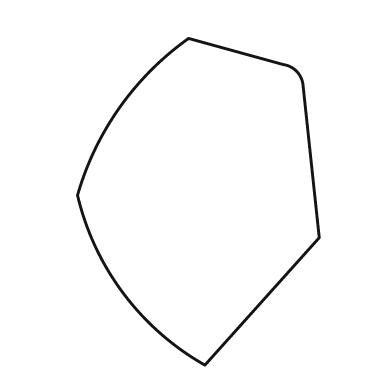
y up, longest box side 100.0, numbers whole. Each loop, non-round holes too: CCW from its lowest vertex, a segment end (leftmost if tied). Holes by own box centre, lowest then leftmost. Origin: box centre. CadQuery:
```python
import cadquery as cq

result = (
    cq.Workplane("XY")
    .moveTo(2.0, -50.0)
    .lineTo(37.0, -11.0)
    .lineTo(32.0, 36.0)
    .threePointArc((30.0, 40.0), (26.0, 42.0))
    .lineTo(-3.0, 50.0)
    .threePointArc((-24.0, 29.0), (-37.0, 2.0))
    .threePointArc((-23.0, -28.0), (2.0, -50.0))
    .close()
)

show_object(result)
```